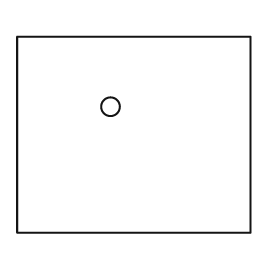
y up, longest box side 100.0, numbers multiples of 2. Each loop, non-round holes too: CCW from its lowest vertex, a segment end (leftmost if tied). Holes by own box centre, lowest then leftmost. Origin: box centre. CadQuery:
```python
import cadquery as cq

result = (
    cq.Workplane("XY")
    .moveTo(-50.0, -42.0)
    .lineTo(50.0, -42.0)
    .lineTo(50.0, 42.0)
    .lineTo(-50.0, 42.0)
    .close()
    .moveTo(-10.0, 12.0)
    .circle(4.0)
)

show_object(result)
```